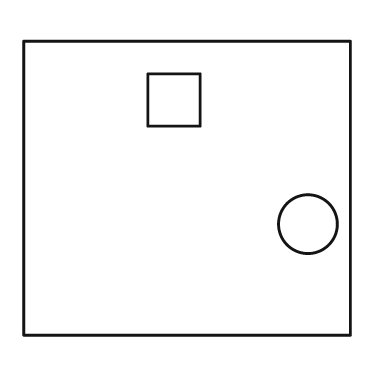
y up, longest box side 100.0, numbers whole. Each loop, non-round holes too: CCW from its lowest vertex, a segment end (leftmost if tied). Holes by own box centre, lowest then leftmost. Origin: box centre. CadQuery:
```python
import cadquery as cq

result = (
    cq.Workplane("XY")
    .moveTo(-50.0, -45.0)
    .lineTo(50.0, -45.0)
    .lineTo(50.0, 45.0)
    .lineTo(-50.0, 45.0)
    .close()
    .moveTo(37.0, -11.0)
    .circle(9.0)
    .moveTo(-12.0, 19.0)
    .lineTo(4.0, 19.0)
    .lineTo(4.0, 35.0)
    .lineTo(-12.0, 35.0)
    .close()
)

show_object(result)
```